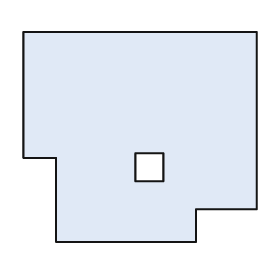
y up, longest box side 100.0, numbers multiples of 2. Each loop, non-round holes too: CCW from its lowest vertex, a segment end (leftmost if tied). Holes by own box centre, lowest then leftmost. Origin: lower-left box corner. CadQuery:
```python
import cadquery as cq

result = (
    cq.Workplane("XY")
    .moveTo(14.0, 0.0)
    .lineTo(74.0, 0.0)
    .lineTo(74.0, 14.0)
    .lineTo(100.0, 14.0)
    .lineTo(100.0, 90.0)
    .lineTo(0.0, 90.0)
    .lineTo(0.0, 36.0)
    .lineTo(14.0, 36.0)
    .close()
    .moveTo(48.0, 26.0)
    .lineTo(60.0, 26.0)
    .lineTo(60.0, 38.0)
    .lineTo(48.0, 38.0)
    .close()
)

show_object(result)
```